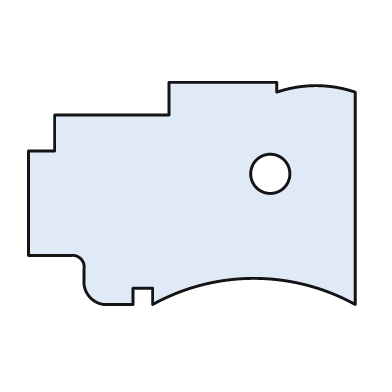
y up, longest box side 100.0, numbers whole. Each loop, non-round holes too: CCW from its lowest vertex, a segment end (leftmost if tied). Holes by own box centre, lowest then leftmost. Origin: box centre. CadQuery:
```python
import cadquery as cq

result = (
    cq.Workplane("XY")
    .moveTo(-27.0, -34.0)
    .lineTo(-18.0, -34.0)
    .lineTo(-18.0, -29.0)
    .lineTo(-12.0, -29.0)
    .lineTo(-12.0, -34.0)
    .threePointArc((19.0, -26.0), (50.0, -34.0))
    .lineTo(50.0, 31.0)
    .threePointArc((38.0, 33.0), (26.0, 31.0))
    .lineTo(26.0, 34.0)
    .lineTo(-7.0, 34.0)
    .lineTo(-7.0, 24.0)
    .lineTo(-42.0, 24.0)
    .lineTo(-42.0, 13.0)
    .lineTo(-50.0, 13.0)
    .lineTo(-50.0, -19.0)
    .lineTo(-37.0, -19.0)
    .threePointArc((-34.0, -20.0), (-33.0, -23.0))
    .lineTo(-33.0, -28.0)
    .threePointArc((-31.0, -32.0), (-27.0, -34.0))
    .close()
    .moveTo(24.0, 6.0)
    .circle(6.0)
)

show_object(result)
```